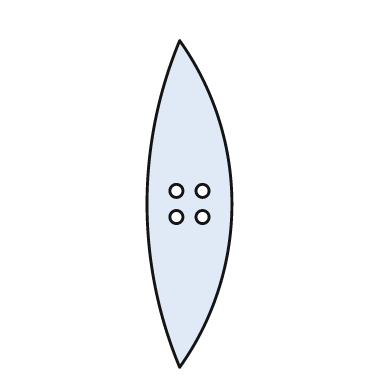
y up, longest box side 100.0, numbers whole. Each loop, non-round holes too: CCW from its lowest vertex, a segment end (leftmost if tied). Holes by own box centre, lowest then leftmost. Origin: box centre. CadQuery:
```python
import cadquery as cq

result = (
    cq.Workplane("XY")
    .moveTo(-3.0, -50.0)
    .threePointArc((13.0, 0.0), (-3.0, 50.0))
    .threePointArc((-13.0, 0.0), (-3.0, -50.0))
    .close()
    .moveTo(-4.0, -4.0)
    .circle(2.0)
    .moveTo(4.0, -4.0)
    .circle(2.0)
    .moveTo(-4.0, 4.0)
    .circle(2.0)
    .moveTo(4.0, 4.0)
    .circle(2.0)
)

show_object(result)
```